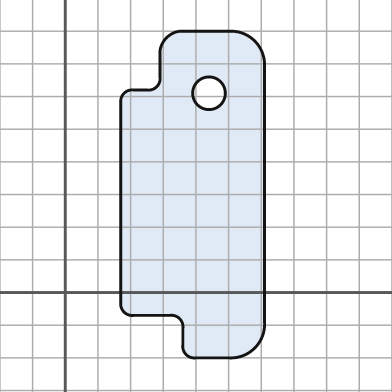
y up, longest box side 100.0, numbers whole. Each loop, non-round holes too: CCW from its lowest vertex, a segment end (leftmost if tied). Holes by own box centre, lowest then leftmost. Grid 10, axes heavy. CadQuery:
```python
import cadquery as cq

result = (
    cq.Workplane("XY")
    .moveTo(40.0, -20.0)
    .lineTo(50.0, -20.0)
    .threePointArc((58.0, -17.0), (61.0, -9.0))
    .lineTo(61.0, 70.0)
    .threePointArc((58.0, 77.0), (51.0, 80.0))
    .lineTo(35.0, 80.0)
    .threePointArc((31.0, 78.0), (29.0, 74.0))
    .lineTo(29.0, 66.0)
    .threePointArc((28.0, 63.0), (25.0, 62.0))
    .lineTo(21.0, 62.0)
    .threePointArc((18.0, 61.0), (17.0, 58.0))
    .lineTo(17.0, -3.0)
    .threePointArc((18.0, -6.0), (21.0, -7.0))
    .lineTo(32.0, -7.0)
    .threePointArc((35.0, -8.0), (36.0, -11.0))
    .lineTo(36.0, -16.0)
    .threePointArc((37.0, -19.0), (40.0, -20.0))
    .close()
    .moveTo(44.0, 61.0)
    .circle(5.0)
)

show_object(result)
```